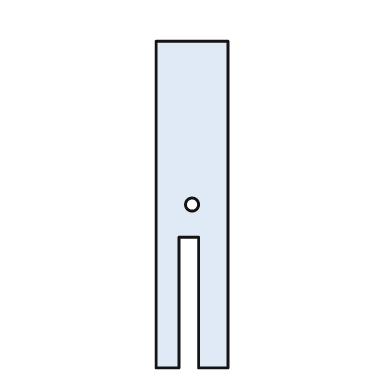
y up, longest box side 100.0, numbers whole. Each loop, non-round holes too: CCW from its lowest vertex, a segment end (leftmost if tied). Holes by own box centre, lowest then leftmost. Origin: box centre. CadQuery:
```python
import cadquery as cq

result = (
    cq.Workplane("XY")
    .moveTo(-11.0, -50.0)
    .lineTo(-4.0, -50.0)
    .lineTo(-4.0, -10.0)
    .lineTo(2.0, -10.0)
    .lineTo(2.0, -50.0)
    .lineTo(11.0, -50.0)
    .lineTo(11.0, 50.0)
    .lineTo(-11.0, 50.0)
    .close()
    .moveTo(0.0, 0.0)
    .circle(2.0)
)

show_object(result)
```